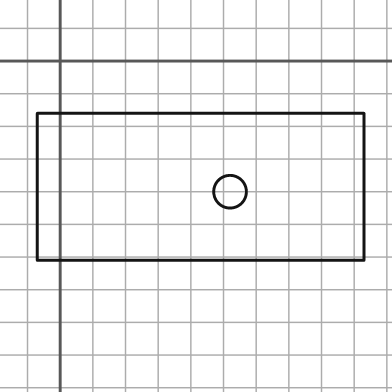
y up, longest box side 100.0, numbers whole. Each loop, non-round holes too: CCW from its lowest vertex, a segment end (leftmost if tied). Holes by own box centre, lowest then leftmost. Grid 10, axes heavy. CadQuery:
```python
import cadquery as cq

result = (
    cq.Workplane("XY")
    .moveTo(-7.0, -61.0)
    .lineTo(93.0, -61.0)
    .lineTo(93.0, -16.0)
    .lineTo(-7.0, -16.0)
    .close()
    .moveTo(52.0, -40.0)
    .circle(5.0)
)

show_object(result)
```